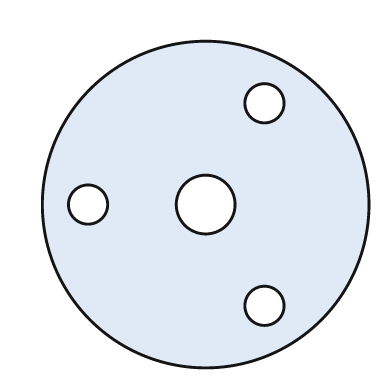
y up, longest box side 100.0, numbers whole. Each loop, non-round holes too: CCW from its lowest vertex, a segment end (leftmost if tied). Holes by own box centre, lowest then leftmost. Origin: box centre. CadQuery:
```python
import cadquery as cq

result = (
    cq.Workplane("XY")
    .moveTo(0.0, 0.0)
    .circle(50.0)
    .moveTo(18.0, -31.0)
    .circle(6.0)
    .moveTo(-36.0, 0.0)
    .circle(6.0)
    .moveTo(0.0, 0.0)
    .circle(9.0)
    .moveTo(18.0, 31.0)
    .circle(6.0)
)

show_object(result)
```